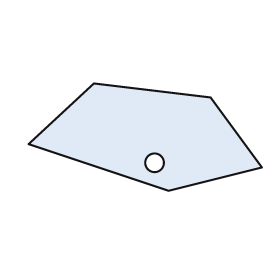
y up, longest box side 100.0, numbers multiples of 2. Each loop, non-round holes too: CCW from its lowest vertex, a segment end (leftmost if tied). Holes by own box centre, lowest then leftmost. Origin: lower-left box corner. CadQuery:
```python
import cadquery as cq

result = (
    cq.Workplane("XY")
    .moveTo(60.0, 0.0)
    .lineTo(100.0, 10.0)
    .lineTo(78.0, 40.0)
    .lineTo(28.0, 46.0)
    .lineTo(0.0, 20.0)
    .close()
    .moveTo(54.0, 12.0)
    .circle(4.0)
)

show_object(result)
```